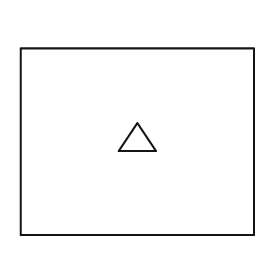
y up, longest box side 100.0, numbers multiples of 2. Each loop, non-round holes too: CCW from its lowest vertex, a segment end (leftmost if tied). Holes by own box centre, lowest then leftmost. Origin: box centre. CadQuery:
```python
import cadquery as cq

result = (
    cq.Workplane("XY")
    .moveTo(-50.0, -40.0)
    .lineTo(50.0, -40.0)
    .lineTo(50.0, 40.0)
    .lineTo(-50.0, 40.0)
    .close()
    .moveTo(-8.0, -4.0)
    .lineTo(8.0, -4.0)
    .lineTo(0.0, 8.0)
    .close()
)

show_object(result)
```